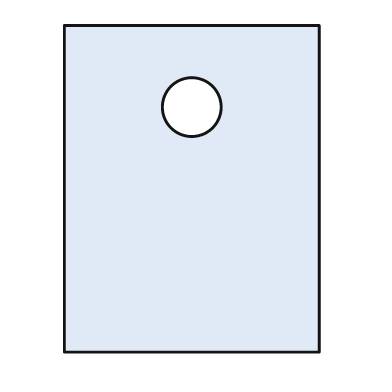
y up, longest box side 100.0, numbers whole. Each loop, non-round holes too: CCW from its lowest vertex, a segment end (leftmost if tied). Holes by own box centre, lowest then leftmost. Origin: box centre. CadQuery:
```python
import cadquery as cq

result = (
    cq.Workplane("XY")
    .moveTo(-39.0, -50.0)
    .lineTo(39.0, -50.0)
    .lineTo(39.0, 50.0)
    .lineTo(-39.0, 50.0)
    .close()
    .moveTo(0.0, 25.0)
    .circle(9.0)
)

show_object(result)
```